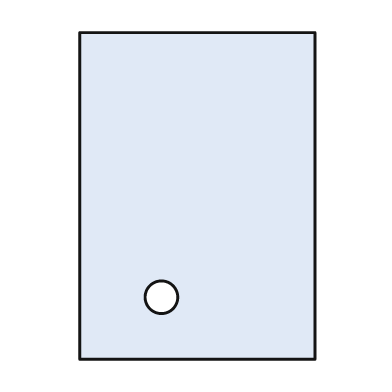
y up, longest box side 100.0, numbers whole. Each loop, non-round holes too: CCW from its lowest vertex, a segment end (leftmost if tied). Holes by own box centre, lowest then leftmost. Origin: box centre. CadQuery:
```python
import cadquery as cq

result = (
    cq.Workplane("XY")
    .moveTo(-36.0, -50.0)
    .lineTo(36.0, -50.0)
    .lineTo(36.0, 50.0)
    .lineTo(-36.0, 50.0)
    .close()
    .moveTo(-11.0, -31.0)
    .circle(5.0)
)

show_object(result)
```